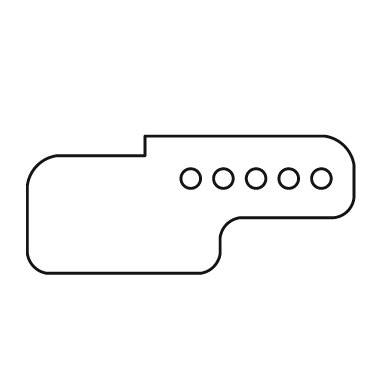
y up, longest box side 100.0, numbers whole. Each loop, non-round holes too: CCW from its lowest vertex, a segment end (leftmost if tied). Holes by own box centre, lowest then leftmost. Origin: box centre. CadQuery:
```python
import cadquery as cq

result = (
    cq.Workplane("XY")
    .moveTo(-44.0, -21.0)
    .lineTo(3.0, -21.0)
    .threePointArc((7.0, -19.0), (9.0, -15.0))
    .lineTo(9.0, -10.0)
    .threePointArc((11.0, -6.0), (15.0, -4.0))
    .lineTo(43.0, -4.0)
    .threePointArc((48.0, -2.0), (50.0, 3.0))
    .lineTo(50.0, 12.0)
    .threePointArc((47.0, 18.0), (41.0, 21.0))
    .lineTo(-14.0, 21.0)
    .lineTo(-14.0, 15.0)
    .lineTo(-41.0, 15.0)
    .threePointArc((-47.0, 12.0), (-50.0, 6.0))
    .lineTo(-50.0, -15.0)
    .threePointArc((-48.0, -19.0), (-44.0, -21.0))
    .close()
    .moveTo(0.0, 8.0)
    .circle(3.0)
    .moveTo(10.0, 8.0)
    .circle(3.0)
    .moveTo(20.0, 8.0)
    .circle(3.0)
    .moveTo(30.0, 8.0)
    .circle(3.0)
    .moveTo(40.0, 8.0)
    .circle(3.0)
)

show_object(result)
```